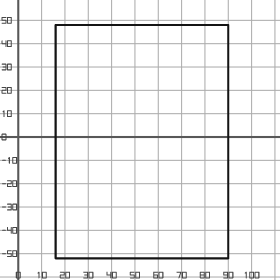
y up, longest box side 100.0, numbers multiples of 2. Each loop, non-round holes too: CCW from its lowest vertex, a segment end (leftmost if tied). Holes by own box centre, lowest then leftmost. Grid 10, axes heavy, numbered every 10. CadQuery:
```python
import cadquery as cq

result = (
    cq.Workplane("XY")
    .moveTo(16.0, -52.0)
    .lineTo(90.0, -52.0)
    .lineTo(90.0, 48.0)
    .lineTo(16.0, 48.0)
    .close()
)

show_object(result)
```